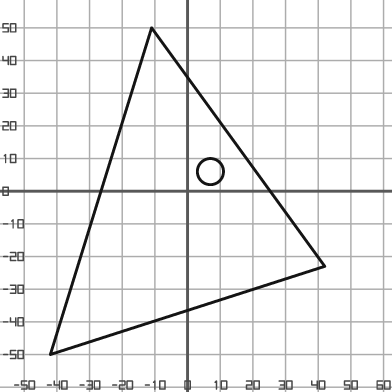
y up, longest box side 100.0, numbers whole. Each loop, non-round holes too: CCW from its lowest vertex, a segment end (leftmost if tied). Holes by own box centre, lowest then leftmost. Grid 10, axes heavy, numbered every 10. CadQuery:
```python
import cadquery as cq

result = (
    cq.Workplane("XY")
    .moveTo(-42.0, -50.0)
    .lineTo(42.0, -23.0)
    .lineTo(-11.0, 50.0)
    .close()
    .moveTo(7.0, 6.0)
    .circle(4.0)
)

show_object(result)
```